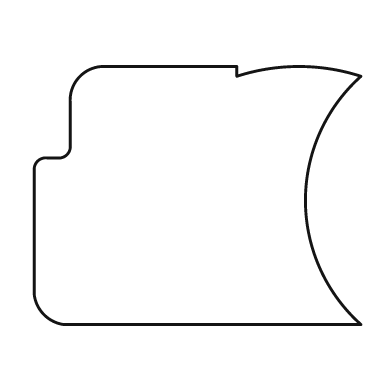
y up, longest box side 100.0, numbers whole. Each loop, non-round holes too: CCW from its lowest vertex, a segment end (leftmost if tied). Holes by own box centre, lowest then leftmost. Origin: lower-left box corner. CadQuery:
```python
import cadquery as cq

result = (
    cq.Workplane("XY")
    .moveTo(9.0, 0.0)
    .lineTo(100.0, 0.0)
    .threePointArc((83.0, 38.0), (100.0, 76.0))
    .threePointArc((81.0, 79.0), (62.0, 76.0))
    .lineTo(62.0, 79.0)
    .lineTo(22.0, 79.0)
    .threePointArc((14.0, 76.0), (11.0, 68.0))
    .lineTo(11.0, 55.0)
    .threePointArc((10.0, 52.0), (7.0, 51.0))
    .lineTo(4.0, 51.0)
    .threePointArc((1.0, 50.0), (0.0, 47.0))
    .lineTo(0.0, 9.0)
    .threePointArc((3.0, 3.0), (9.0, 0.0))
    .close()
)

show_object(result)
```